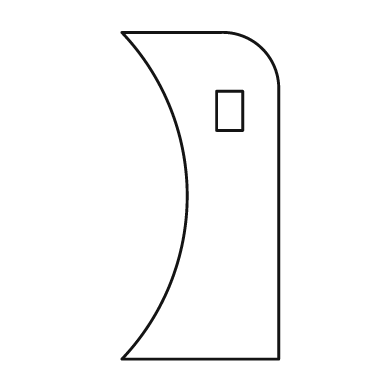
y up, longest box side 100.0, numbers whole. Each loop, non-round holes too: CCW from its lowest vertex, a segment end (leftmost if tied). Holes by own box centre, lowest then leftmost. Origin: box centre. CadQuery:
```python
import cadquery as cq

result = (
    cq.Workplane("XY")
    .moveTo(-24.0, -50.0)
    .lineTo(24.0, -50.0)
    .lineTo(24.0, 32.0)
    .threePointArc((19.0, 45.0), (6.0, 50.0))
    .lineTo(-24.0, 50.0)
    .threePointArc((-4.0, 0.0), (-24.0, -50.0))
    .close()
    .moveTo(5.0, 20.0)
    .lineTo(13.0, 20.0)
    .lineTo(13.0, 32.0)
    .lineTo(5.0, 32.0)
    .close()
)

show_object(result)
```